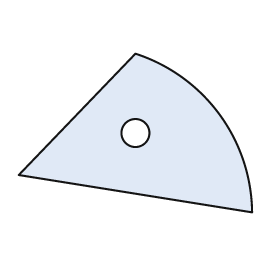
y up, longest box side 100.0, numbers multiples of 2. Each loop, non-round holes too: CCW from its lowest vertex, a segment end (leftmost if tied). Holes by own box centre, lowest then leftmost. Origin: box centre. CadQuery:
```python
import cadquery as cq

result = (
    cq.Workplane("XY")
    .moveTo(50.0, -34.0)
    .threePointArc((36.0, 8.0), (0.0, 34.0))
    .lineTo(-50.0, -18.0)
    .close()
    .moveTo(0.0, 0.0)
    .circle(6.0)
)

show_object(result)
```